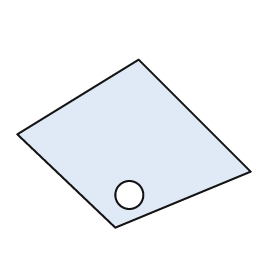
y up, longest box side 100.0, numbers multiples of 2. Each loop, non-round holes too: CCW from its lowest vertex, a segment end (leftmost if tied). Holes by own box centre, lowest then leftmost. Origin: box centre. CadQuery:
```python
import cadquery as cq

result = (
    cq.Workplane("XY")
    .moveTo(-8.0, -36.0)
    .lineTo(50.0, -12.0)
    .lineTo(2.0, 36.0)
    .lineTo(-50.0, 4.0)
    .close()
    .moveTo(-2.0, -22.0)
    .circle(6.0)
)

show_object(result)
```